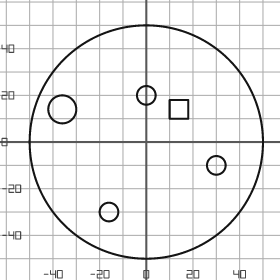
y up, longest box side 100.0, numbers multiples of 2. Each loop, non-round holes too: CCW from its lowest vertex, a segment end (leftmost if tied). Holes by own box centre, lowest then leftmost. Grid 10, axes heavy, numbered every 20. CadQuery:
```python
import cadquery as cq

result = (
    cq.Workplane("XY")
    .moveTo(0.0, 0.0)
    .circle(50.0)
    .moveTo(-16.0, -30.0)
    .circle(4.0)
    .moveTo(30.0, -10.0)
    .circle(4.0)
    .moveTo(-36.0, 14.0)
    .circle(6.0)
    .moveTo(10.0, 10.0)
    .lineTo(18.0, 10.0)
    .lineTo(18.0, 18.0)
    .lineTo(10.0, 18.0)
    .close()
    .moveTo(0.0, 20.0)
    .circle(4.0)
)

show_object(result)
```